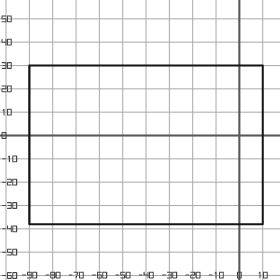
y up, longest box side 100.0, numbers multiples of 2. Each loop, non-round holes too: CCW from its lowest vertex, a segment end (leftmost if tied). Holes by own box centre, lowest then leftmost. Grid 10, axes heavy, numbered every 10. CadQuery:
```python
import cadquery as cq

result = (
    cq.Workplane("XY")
    .moveTo(-90.0, -38.0)
    .lineTo(10.0, -38.0)
    .lineTo(10.0, 30.0)
    .lineTo(-90.0, 30.0)
    .close()
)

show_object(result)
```